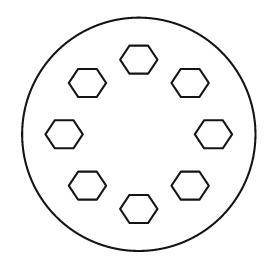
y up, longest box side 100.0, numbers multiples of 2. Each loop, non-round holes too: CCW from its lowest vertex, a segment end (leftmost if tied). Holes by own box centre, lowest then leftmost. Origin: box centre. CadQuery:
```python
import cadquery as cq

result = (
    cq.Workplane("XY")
    .moveTo(0.0, 0.0)
    .circle(50.0)
    .moveTo(-4.0, -38.0)
    .lineTo(4.0, -38.0)
    .lineTo(8.0, -32.0)
    .lineTo(4.0, -26.0)
    .lineTo(-4.0, -26.0)
    .lineTo(-8.0, -32.0)
    .close()
    .moveTo(-26.0, -28.0)
    .lineTo(-18.0, -28.0)
    .lineTo(-14.0, -22.0)
    .lineTo(-18.0, -16.0)
    .lineTo(-26.0, -16.0)
    .lineTo(-30.0, -22.0)
    .close()
    .moveTo(18.0, -28.0)
    .lineTo(26.0, -28.0)
    .lineTo(30.0, -22.0)
    .lineTo(26.0, -16.0)
    .lineTo(18.0, -16.0)
    .lineTo(14.0, -22.0)
    .close()
    .moveTo(-36.0, -6.0)
    .lineTo(-28.0, -6.0)
    .lineTo(-24.0, 0.0)
    .lineTo(-28.0, 6.0)
    .lineTo(-36.0, 6.0)
    .lineTo(-40.0, 0.0)
    .close()
    .moveTo(28.0, -6.0)
    .lineTo(36.0, -6.0)
    .lineTo(40.0, 0.0)
    .lineTo(36.0, 6.0)
    .lineTo(28.0, 6.0)
    .lineTo(24.0, 0.0)
    .close()
    .moveTo(-26.0, 16.0)
    .lineTo(-18.0, 16.0)
    .lineTo(-14.0, 22.0)
    .lineTo(-18.0, 28.0)
    .lineTo(-26.0, 28.0)
    .lineTo(-30.0, 22.0)
    .close()
    .moveTo(18.0, 16.0)
    .lineTo(26.0, 16.0)
    .lineTo(30.0, 22.0)
    .lineTo(26.0, 28.0)
    .lineTo(18.0, 28.0)
    .lineTo(14.0, 22.0)
    .close()
    .moveTo(-4.0, 26.0)
    .lineTo(4.0, 26.0)
    .lineTo(8.0, 32.0)
    .lineTo(4.0, 38.0)
    .lineTo(-4.0, 38.0)
    .lineTo(-8.0, 32.0)
    .close()
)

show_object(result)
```